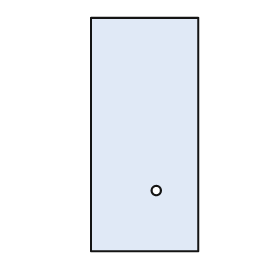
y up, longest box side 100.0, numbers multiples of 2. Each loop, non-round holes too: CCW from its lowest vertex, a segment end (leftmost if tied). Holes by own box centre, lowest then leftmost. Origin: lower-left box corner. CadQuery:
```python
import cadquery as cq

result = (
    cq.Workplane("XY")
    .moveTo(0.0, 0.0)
    .lineTo(46.0, 0.0)
    .lineTo(46.0, 100.0)
    .lineTo(0.0, 100.0)
    .close()
    .moveTo(28.0, 26.0)
    .circle(2.0)
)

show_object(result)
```